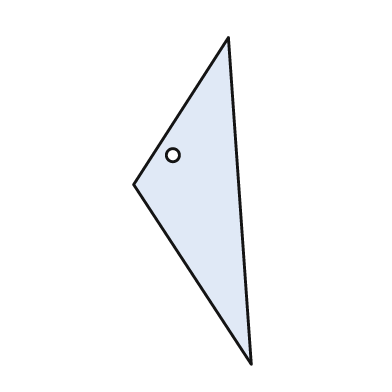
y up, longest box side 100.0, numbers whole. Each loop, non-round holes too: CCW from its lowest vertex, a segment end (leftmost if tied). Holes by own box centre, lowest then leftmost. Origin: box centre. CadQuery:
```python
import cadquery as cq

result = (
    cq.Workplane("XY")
    .moveTo(18.0, -50.0)
    .lineTo(11.0, 50.0)
    .lineTo(-18.0, 5.0)
    .close()
    .moveTo(-6.0, 14.0)
    .circle(2.0)
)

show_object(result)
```